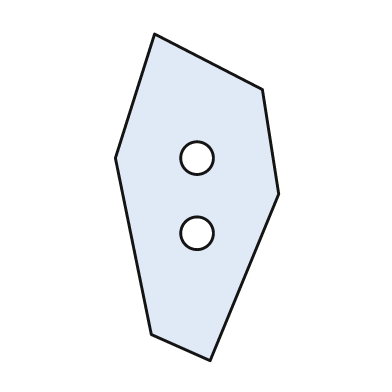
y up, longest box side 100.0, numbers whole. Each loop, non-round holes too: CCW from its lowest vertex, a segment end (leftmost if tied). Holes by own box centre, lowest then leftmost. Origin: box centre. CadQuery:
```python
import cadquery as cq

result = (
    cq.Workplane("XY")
    .moveTo(4.0, -50.0)
    .lineTo(25.0, 1.0)
    .lineTo(20.0, 33.0)
    .lineTo(-13.0, 50.0)
    .lineTo(-25.0, 12.0)
    .lineTo(-14.0, -42.0)
    .close()
    .moveTo(0.0, -11.0)
    .circle(5.0)
    .moveTo(0.0, 12.0)
    .circle(5.0)
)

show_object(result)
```